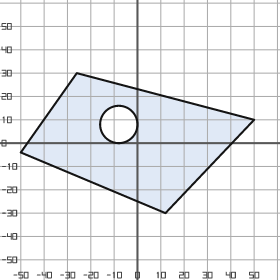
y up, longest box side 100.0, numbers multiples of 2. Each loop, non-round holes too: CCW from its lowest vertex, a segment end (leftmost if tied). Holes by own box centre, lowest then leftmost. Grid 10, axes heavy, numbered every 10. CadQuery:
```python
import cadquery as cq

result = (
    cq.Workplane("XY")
    .moveTo(12.0, -30.0)
    .lineTo(50.0, 10.0)
    .lineTo(-26.0, 30.0)
    .lineTo(-50.0, -4.0)
    .close()
    .moveTo(-8.0, 8.0)
    .circle(8.0)
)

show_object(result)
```